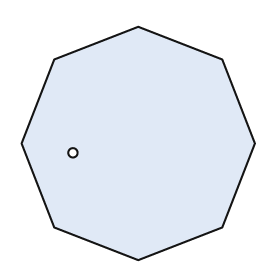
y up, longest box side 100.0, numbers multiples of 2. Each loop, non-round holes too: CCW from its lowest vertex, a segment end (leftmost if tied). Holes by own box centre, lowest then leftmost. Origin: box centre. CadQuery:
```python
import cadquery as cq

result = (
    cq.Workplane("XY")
    .moveTo(0.0, -50.0)
    .lineTo(36.0, -36.0)
    .lineTo(50.0, 0.0)
    .lineTo(36.0, 36.0)
    .lineTo(0.0, 50.0)
    .lineTo(-36.0, 36.0)
    .lineTo(-50.0, 0.0)
    .lineTo(-36.0, -36.0)
    .close()
    .moveTo(-28.0, -4.0)
    .circle(2.0)
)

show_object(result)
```